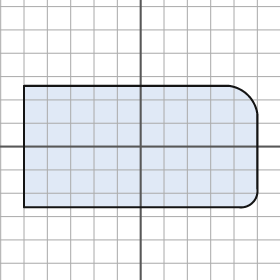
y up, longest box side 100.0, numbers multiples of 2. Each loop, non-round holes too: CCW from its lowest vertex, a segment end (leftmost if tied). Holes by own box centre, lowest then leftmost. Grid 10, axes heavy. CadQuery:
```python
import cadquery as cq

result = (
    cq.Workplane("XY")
    .moveTo(-50.0, -26.0)
    .lineTo(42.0, -26.0)
    .threePointArc((48.0, -24.0), (50.0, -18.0))
    .lineTo(50.0, 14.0)
    .threePointArc((46.0, 22.0), (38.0, 26.0))
    .lineTo(-50.0, 26.0)
    .close()
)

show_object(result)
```